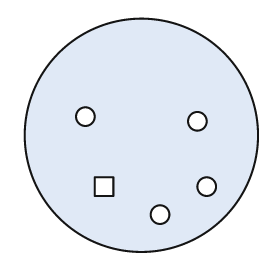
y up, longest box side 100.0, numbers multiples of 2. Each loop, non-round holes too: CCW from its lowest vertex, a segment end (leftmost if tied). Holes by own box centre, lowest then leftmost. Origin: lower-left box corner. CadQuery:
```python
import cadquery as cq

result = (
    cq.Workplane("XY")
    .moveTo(50.0, 50.0)
    .circle(50.0)
    .moveTo(58.0, 16.0)
    .circle(4.0)
    .moveTo(30.0, 24.0)
    .lineTo(38.0, 24.0)
    .lineTo(38.0, 32.0)
    .lineTo(30.0, 32.0)
    .close()
    .moveTo(78.0, 28.0)
    .circle(4.0)
    .moveTo(74.0, 56.0)
    .circle(4.0)
    .moveTo(26.0, 58.0)
    .circle(4.0)
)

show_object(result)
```